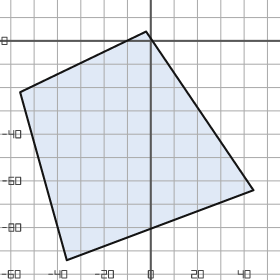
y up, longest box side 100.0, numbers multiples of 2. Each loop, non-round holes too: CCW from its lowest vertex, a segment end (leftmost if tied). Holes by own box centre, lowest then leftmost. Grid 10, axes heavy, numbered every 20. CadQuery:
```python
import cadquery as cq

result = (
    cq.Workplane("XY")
    .moveTo(-36.0, -94.0)
    .lineTo(44.0, -64.0)
    .lineTo(-2.0, 4.0)
    .lineTo(-56.0, -22.0)
    .close()
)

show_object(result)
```